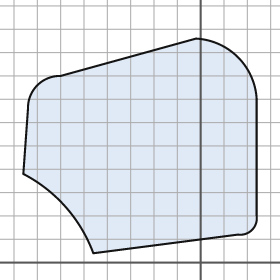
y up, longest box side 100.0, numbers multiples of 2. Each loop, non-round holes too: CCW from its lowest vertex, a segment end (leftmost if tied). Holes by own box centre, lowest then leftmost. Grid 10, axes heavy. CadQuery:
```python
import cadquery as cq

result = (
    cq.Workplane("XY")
    .moveTo(-46.0, 4.0)
    .lineTo(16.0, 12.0)
    .threePointArc((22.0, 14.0), (24.0, 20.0))
    .lineTo(24.0, 70.0)
    .threePointArc((16.0, 88.0), (-2.0, 96.0))
    .lineTo(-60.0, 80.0)
    .threePointArc((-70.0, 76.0), (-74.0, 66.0))
    .lineTo(-76.0, 38.0)
    .threePointArc((-58.0, 24.0), (-46.0, 4.0))
    .close()
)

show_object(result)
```